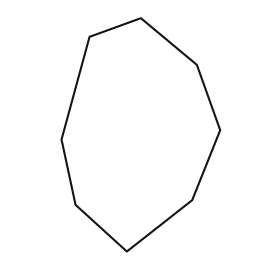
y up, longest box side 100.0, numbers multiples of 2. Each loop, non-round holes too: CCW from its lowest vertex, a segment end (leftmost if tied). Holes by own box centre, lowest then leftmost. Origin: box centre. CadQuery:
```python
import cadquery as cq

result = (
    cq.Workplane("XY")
    .moveTo(-6.0, -50.0)
    .lineTo(22.0, -28.0)
    .lineTo(34.0, 2.0)
    .lineTo(24.0, 30.0)
    .lineTo(0.0, 50.0)
    .lineTo(-22.0, 42.0)
    .lineTo(-34.0, -2.0)
    .lineTo(-28.0, -30.0)
    .close()
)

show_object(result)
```